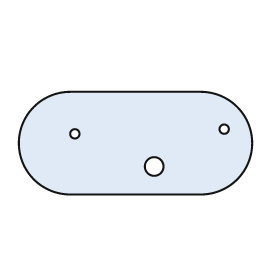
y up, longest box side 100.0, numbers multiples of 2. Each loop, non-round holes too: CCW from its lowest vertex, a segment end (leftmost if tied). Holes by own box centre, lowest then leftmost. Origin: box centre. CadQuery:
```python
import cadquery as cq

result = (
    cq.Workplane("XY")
    .moveTo(-28.0, -22.0)
    .lineTo(28.0, -22.0)
    .threePointArc((50.0, 0.0), (28.0, 22.0))
    .lineTo(-28.0, 22.0)
    .threePointArc((-50.0, 0.0), (-28.0, -22.0))
    .close()
    .moveTo(8.0, -10.0)
    .circle(4.0)
    .moveTo(-26.0, 4.0)
    .circle(2.0)
    .moveTo(38.0, 6.0)
    .circle(2.0)
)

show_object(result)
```